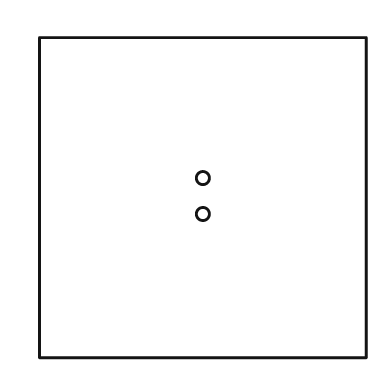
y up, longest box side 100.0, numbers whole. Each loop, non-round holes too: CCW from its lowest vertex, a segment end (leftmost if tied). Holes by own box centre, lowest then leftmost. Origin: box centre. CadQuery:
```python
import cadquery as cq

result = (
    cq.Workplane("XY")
    .moveTo(-50.0, -49.0)
    .lineTo(50.0, -49.0)
    .lineTo(50.0, 49.0)
    .lineTo(-50.0, 49.0)
    .close()
    .moveTo(0.0, -5.0)
    .circle(2.0)
    .moveTo(0.0, 6.0)
    .circle(2.0)
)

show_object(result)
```